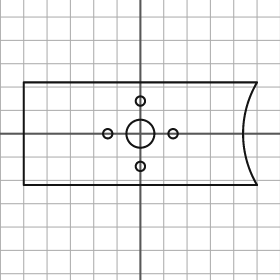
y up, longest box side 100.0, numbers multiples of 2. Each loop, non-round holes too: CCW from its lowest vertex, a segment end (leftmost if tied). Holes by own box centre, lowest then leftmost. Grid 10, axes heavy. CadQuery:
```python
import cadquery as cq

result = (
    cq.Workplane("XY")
    .moveTo(-50.0, -22.0)
    .lineTo(50.0, -22.0)
    .threePointArc((44.0, 0.0), (50.0, 22.0))
    .lineTo(-50.0, 22.0)
    .close()
    .moveTo(0.0, -14.0)
    .circle(2.0)
    .moveTo(-14.0, 0.0)
    .circle(2.0)
    .moveTo(0.0, 0.0)
    .circle(6.0)
    .moveTo(14.0, 0.0)
    .circle(2.0)
    .moveTo(0.0, 14.0)
    .circle(2.0)
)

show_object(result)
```